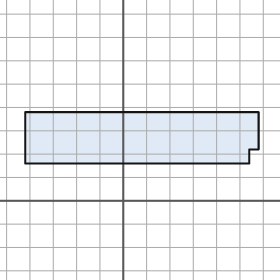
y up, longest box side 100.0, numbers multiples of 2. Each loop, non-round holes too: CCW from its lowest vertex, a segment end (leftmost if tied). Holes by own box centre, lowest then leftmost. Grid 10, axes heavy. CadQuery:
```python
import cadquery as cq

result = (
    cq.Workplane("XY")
    .moveTo(-42.0, 16.0)
    .lineTo(54.0, 16.0)
    .lineTo(54.0, 22.0)
    .lineTo(58.0, 22.0)
    .lineTo(58.0, 38.0)
    .lineTo(-42.0, 38.0)
    .close()
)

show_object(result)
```